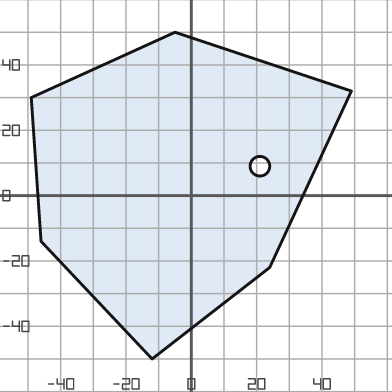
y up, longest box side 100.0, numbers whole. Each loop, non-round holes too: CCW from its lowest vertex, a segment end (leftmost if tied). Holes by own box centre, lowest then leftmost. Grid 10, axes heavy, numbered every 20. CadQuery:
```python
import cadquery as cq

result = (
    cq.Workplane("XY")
    .moveTo(-12.0, -50.0)
    .lineTo(24.0, -22.0)
    .lineTo(49.0, 32.0)
    .lineTo(-5.0, 50.0)
    .lineTo(-49.0, 30.0)
    .lineTo(-46.0, -14.0)
    .close()
    .moveTo(21.0, 9.0)
    .circle(3.0)
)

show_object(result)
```